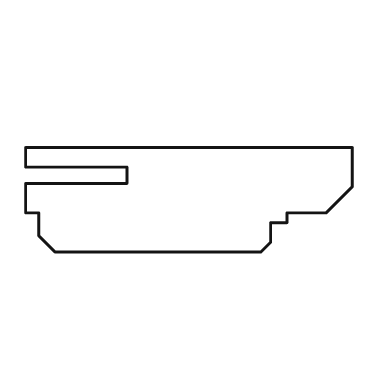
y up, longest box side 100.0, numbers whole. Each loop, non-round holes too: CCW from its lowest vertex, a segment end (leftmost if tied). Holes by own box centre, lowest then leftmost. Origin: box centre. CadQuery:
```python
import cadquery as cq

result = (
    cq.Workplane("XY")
    .moveTo(-41.0, -16.0)
    .lineTo(22.0, -16.0)
    .lineTo(25.0, -13.0)
    .lineTo(25.0, -7.0)
    .lineTo(30.0, -7.0)
    .lineTo(30.0, -4.0)
    .lineTo(42.0, -4.0)
    .lineTo(50.0, 4.0)
    .lineTo(50.0, 16.0)
    .lineTo(-50.0, 16.0)
    .lineTo(-50.0, 10.0)
    .lineTo(-19.0, 10.0)
    .lineTo(-19.0, 5.0)
    .lineTo(-50.0, 5.0)
    .lineTo(-50.0, -4.0)
    .lineTo(-46.0, -4.0)
    .lineTo(-46.0, -11.0)
    .close()
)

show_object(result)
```